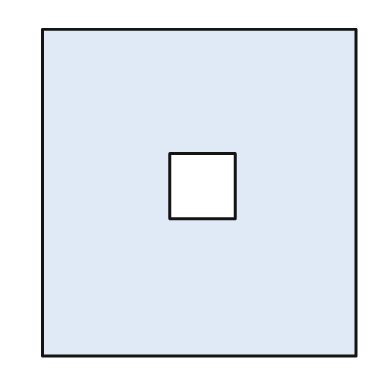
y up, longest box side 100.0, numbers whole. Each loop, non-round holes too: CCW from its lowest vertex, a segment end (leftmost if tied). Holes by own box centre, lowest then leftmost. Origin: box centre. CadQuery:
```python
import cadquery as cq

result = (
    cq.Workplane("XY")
    .moveTo(-48.0, -50.0)
    .lineTo(48.0, -50.0)
    .lineTo(48.0, 50.0)
    .lineTo(-48.0, 50.0)
    .close()
    .moveTo(-9.0, -8.0)
    .lineTo(11.0, -8.0)
    .lineTo(11.0, 12.0)
    .lineTo(-9.0, 12.0)
    .close()
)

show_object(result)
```